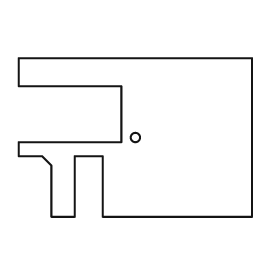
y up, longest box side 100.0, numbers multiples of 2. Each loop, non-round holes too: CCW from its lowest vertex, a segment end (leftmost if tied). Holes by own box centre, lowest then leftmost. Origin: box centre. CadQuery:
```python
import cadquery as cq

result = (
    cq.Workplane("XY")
    .moveTo(-36.0, -34.0)
    .lineTo(-26.0, -34.0)
    .lineTo(-26.0, -8.0)
    .lineTo(-14.0, -8.0)
    .lineTo(-14.0, -34.0)
    .lineTo(50.0, -34.0)
    .lineTo(50.0, 34.0)
    .lineTo(-50.0, 34.0)
    .lineTo(-50.0, 22.0)
    .lineTo(-6.0, 22.0)
    .lineTo(-6.0, -2.0)
    .lineTo(-50.0, -2.0)
    .lineTo(-50.0, -8.0)
    .lineTo(-40.0, -8.0)
    .lineTo(-36.0, -12.0)
    .close()
    .moveTo(0.0, 0.0)
    .circle(2.0)
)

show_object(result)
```